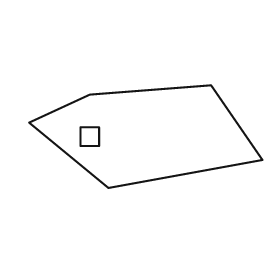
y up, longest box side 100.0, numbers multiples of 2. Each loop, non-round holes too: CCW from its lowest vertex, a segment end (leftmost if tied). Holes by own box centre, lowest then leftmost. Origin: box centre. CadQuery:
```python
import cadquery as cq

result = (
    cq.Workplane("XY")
    .moveTo(-16.0, -22.0)
    .lineTo(50.0, -10.0)
    .lineTo(28.0, 22.0)
    .lineTo(-24.0, 18.0)
    .lineTo(-50.0, 6.0)
    .close()
    .moveTo(-28.0, -4.0)
    .lineTo(-20.0, -4.0)
    .lineTo(-20.0, 4.0)
    .lineTo(-28.0, 4.0)
    .close()
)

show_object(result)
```